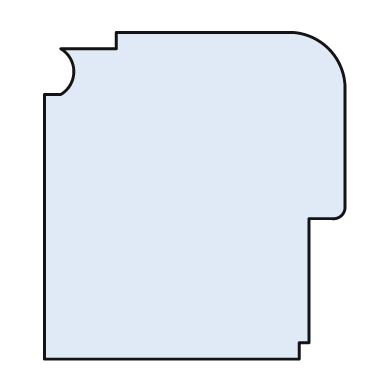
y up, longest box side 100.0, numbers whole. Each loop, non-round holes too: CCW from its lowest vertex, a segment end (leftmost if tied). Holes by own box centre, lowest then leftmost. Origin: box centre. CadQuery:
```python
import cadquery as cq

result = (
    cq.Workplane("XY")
    .moveTo(-46.0, -50.0)
    .lineTo(32.0, -50.0)
    .lineTo(32.0, -45.0)
    .lineTo(35.0, -45.0)
    .lineTo(35.0, -7.0)
    .lineTo(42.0, -7.0)
    .threePointArc((45.0, -6.0), (46.0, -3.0))
    .lineTo(46.0, 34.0)
    .threePointArc((41.0, 45.0), (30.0, 50.0))
    .lineTo(-24.0, 50.0)
    .lineTo(-24.0, 45.0)
    .lineTo(-41.0, 45.0)
    .threePointArc((-37.0, 38.0), (-41.0, 31.0))
    .lineTo(-46.0, 31.0)
    .close()
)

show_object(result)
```